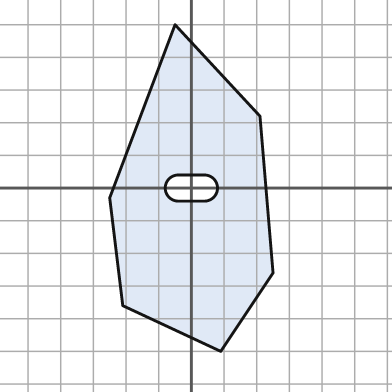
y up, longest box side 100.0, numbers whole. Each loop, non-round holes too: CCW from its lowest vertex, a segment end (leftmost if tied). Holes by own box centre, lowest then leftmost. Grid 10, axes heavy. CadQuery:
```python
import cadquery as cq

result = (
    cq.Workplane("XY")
    .moveTo(9.0, -50.0)
    .lineTo(25.0, -26.0)
    .lineTo(21.0, 22.0)
    .lineTo(-5.0, 50.0)
    .lineTo(-25.0, -3.0)
    .lineTo(-21.0, -36.0)
    .close()
    .moveTo(-4.0, -4.0)
    .lineTo(4.0, -4.0)
    .threePointArc((8.0, 0.0), (4.0, 4.0))
    .lineTo(-4.0, 4.0)
    .threePointArc((-8.0, 0.0), (-4.0, -4.0))
    .close()
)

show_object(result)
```